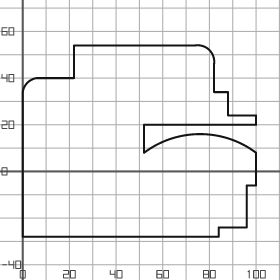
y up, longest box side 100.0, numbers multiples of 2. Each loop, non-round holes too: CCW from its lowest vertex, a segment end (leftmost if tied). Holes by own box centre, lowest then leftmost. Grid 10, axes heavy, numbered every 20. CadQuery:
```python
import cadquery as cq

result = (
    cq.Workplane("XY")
    .moveTo(0.0, -28.0)
    .lineTo(84.0, -28.0)
    .lineTo(84.0, -24.0)
    .lineTo(96.0, -24.0)
    .lineTo(96.0, -6.0)
    .lineTo(100.0, -6.0)
    .lineTo(100.0, 8.0)
    .threePointArc((76.0, 16.0), (52.0, 8.0))
    .lineTo(52.0, 20.0)
    .lineTo(100.0, 20.0)
    .lineTo(100.0, 24.0)
    .lineTo(88.0, 24.0)
    .lineTo(88.0, 34.0)
    .lineTo(82.0, 34.0)
    .lineTo(82.0, 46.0)
    .threePointArc((80.0, 52.0), (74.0, 54.0))
    .lineTo(22.0, 54.0)
    .lineTo(22.0, 40.0)
    .lineTo(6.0, 40.0)
    .threePointArc((2.0, 38.0), (0.0, 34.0))
    .close()
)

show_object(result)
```